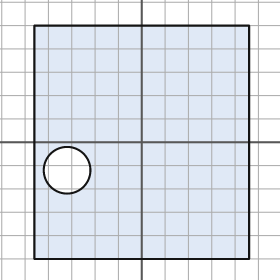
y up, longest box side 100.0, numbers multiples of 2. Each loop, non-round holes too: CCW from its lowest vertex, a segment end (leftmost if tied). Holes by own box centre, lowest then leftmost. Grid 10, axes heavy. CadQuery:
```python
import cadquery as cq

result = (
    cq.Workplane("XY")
    .moveTo(-46.0, -50.0)
    .lineTo(46.0, -50.0)
    .lineTo(46.0, 50.0)
    .lineTo(-46.0, 50.0)
    .close()
    .moveTo(-32.0, -12.0)
    .circle(10.0)
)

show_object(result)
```